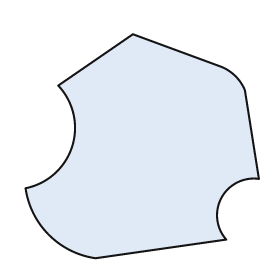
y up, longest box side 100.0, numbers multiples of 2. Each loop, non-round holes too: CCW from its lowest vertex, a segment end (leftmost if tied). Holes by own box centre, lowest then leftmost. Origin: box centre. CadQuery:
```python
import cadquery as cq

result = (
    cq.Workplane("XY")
    .moveTo(-20.0, -48.0)
    .lineTo(36.0, -40.0)
    .threePointArc((34.0, -22.0), (50.0, -14.0))
    .lineTo(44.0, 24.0)
    .threePointArc((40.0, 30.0), (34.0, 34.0))
    .lineTo(-4.0, 48.0)
    .lineTo(-36.0, 26.0)
    .threePointArc((-30.0, 0.0), (-50.0, -18.0))
    .threePointArc((-40.0, -38.0), (-20.0, -48.0))
    .close()
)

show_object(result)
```